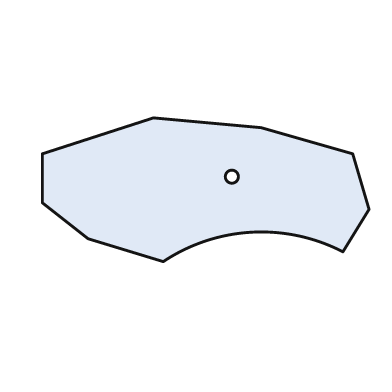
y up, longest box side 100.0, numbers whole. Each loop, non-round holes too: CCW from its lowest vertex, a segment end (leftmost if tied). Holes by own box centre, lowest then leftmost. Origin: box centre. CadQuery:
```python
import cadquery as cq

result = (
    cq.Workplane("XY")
    .moveTo(-13.0, -22.0)
    .threePointArc((14.0, -13.0), (42.0, -19.0))
    .lineTo(50.0, -6.0)
    .lineTo(45.0, 11.0)
    .lineTo(17.0, 19.0)
    .lineTo(-16.0, 22.0)
    .lineTo(-50.0, 11.0)
    .lineTo(-50.0, -4.0)
    .lineTo(-36.0, -15.0)
    .close()
    .moveTo(8.0, 4.0)
    .circle(2.0)
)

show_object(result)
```